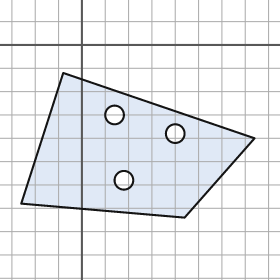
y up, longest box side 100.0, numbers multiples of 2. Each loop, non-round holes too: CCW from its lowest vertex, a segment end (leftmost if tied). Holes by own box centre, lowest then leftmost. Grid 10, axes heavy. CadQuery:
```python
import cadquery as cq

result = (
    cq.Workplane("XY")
    .moveTo(44.0, -74.0)
    .lineTo(74.0, -40.0)
    .lineTo(-8.0, -12.0)
    .lineTo(-26.0, -68.0)
    .close()
    .moveTo(18.0, -58.0)
    .circle(4.0)
    .moveTo(40.0, -38.0)
    .circle(4.0)
    .moveTo(14.0, -30.0)
    .circle(4.0)
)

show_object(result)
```